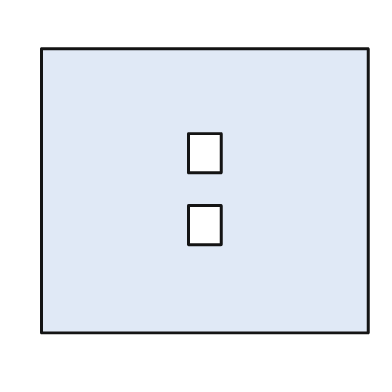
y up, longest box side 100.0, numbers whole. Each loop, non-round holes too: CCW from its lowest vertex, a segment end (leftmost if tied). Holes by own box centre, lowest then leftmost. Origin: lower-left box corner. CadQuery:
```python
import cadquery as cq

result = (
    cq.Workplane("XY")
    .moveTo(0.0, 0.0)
    .lineTo(100.0, 0.0)
    .lineTo(100.0, 87.0)
    .lineTo(0.0, 87.0)
    .close()
    .moveTo(45.0, 27.0)
    .lineTo(55.0, 27.0)
    .lineTo(55.0, 39.0)
    .lineTo(45.0, 39.0)
    .close()
    .moveTo(45.0, 49.0)
    .lineTo(55.0, 49.0)
    .lineTo(55.0, 61.0)
    .lineTo(45.0, 61.0)
    .close()
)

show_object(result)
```